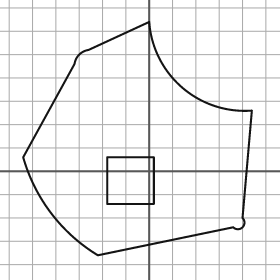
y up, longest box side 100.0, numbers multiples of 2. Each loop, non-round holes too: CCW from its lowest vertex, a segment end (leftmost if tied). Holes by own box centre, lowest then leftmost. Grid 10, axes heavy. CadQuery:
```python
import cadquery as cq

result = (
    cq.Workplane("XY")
    .moveTo(-22.0, -36.0)
    .lineTo(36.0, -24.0)
    .threePointArc((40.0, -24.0), (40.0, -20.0))
    .lineTo(44.0, 26.0)
    .threePointArc((14.0, 36.0), (0.0, 64.0))
    .lineTo(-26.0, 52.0)
    .threePointArc((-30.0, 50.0), (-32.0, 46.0))
    .lineTo(-54.0, 6.0)
    .threePointArc((-42.0, -18.0), (-22.0, -36.0))
    .close()
    .moveTo(-18.0, -14.0)
    .lineTo(2.0, -14.0)
    .lineTo(2.0, 6.0)
    .lineTo(-18.0, 6.0)
    .close()
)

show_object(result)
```